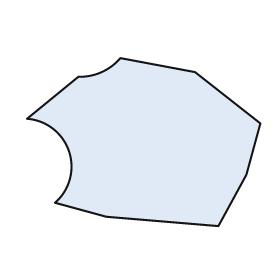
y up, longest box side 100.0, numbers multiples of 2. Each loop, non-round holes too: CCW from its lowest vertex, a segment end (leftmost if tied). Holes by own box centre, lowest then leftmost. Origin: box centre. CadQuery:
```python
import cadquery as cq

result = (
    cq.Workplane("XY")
    .moveTo(32.0, -36.0)
    .lineTo(44.0, -14.0)
    .lineTo(50.0, 8.0)
    .lineTo(22.0, 30.0)
    .lineTo(-10.0, 36.0)
    .threePointArc((-18.0, 30.0), (-28.0, 28.0))
    .lineTo(-50.0, 10.0)
    .threePointArc((-32.0, -4.0), (-38.0, -26.0))
    .lineTo(-16.0, -32.0)
    .close()
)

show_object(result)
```